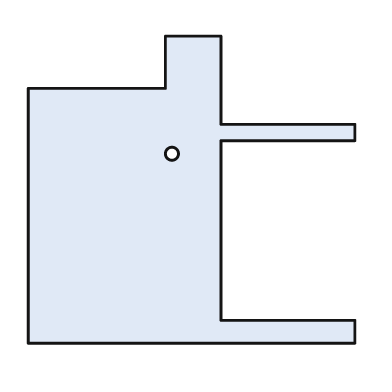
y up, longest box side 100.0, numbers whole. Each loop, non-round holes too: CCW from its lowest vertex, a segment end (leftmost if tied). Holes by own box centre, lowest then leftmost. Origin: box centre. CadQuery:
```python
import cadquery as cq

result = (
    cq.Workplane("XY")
    .moveTo(-50.0, -47.0)
    .lineTo(50.0, -47.0)
    .lineTo(50.0, -40.0)
    .lineTo(9.0, -40.0)
    .lineTo(9.0, 15.0)
    .lineTo(50.0, 15.0)
    .lineTo(50.0, 20.0)
    .lineTo(9.0, 20.0)
    .lineTo(9.0, 47.0)
    .lineTo(-8.0, 47.0)
    .lineTo(-8.0, 31.0)
    .lineTo(-50.0, 31.0)
    .close()
    .moveTo(-6.0, 11.0)
    .circle(2.0)
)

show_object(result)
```